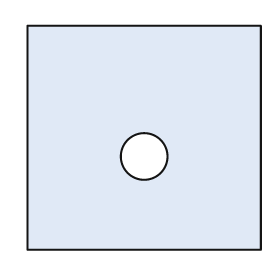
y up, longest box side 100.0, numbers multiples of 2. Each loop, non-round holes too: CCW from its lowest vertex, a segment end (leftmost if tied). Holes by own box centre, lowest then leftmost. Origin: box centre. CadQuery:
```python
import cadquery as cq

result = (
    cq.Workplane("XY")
    .moveTo(-50.0, -48.0)
    .lineTo(50.0, -48.0)
    .lineTo(50.0, 48.0)
    .lineTo(-50.0, 48.0)
    .close()
    .moveTo(0.0, -8.0)
    .circle(10.0)
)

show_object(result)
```